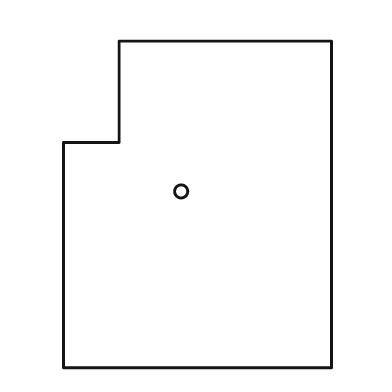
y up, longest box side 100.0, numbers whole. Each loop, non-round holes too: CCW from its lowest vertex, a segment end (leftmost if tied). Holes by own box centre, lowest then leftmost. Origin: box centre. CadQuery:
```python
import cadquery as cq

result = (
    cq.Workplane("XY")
    .moveTo(-41.0, -50.0)
    .lineTo(41.0, -50.0)
    .lineTo(41.0, 50.0)
    .lineTo(-24.0, 50.0)
    .lineTo(-24.0, 19.0)
    .lineTo(-41.0, 19.0)
    .close()
    .moveTo(-5.0, 4.0)
    .circle(2.0)
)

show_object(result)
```